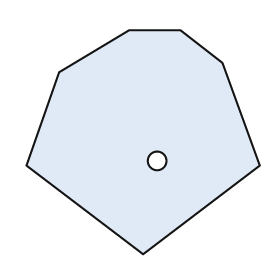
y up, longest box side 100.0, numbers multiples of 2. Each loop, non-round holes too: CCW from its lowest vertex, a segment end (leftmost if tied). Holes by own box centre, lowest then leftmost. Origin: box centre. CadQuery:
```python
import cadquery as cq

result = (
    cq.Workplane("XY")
    .moveTo(0.0, -48.0)
    .lineTo(50.0, -10.0)
    .lineTo(34.0, 34.0)
    .lineTo(16.0, 48.0)
    .lineTo(-6.0, 48.0)
    .lineTo(-36.0, 30.0)
    .lineTo(-50.0, -10.0)
    .close()
    .moveTo(6.0, -8.0)
    .circle(4.0)
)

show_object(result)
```